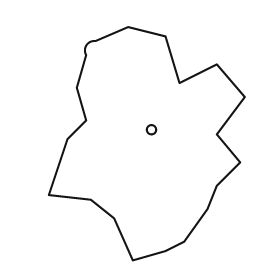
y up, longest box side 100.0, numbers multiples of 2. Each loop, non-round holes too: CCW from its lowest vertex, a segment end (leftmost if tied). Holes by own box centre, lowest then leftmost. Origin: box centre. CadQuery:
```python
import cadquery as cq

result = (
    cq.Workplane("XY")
    .moveTo(-6.0, -50.0)
    .lineTo(8.0, -46.0)
    .lineTo(16.0, -42.0)
    .lineTo(26.0, -28.0)
    .lineTo(30.0, -18.0)
    .lineTo(40.0, -8.0)
    .lineTo(30.0, 4.0)
    .lineTo(42.0, 20.0)
    .lineTo(30.0, 34.0)
    .lineTo(14.0, 26.0)
    .lineTo(8.0, 46.0)
    .lineTo(-8.0, 50.0)
    .lineTo(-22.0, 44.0)
    .threePointArc((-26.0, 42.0), (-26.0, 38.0))
    .lineTo(-30.0, 24.0)
    .lineTo(-26.0, 10.0)
    .lineTo(-34.0, 2.0)
    .lineTo(-42.0, -22.0)
    .lineTo(-24.0, -24.0)
    .lineTo(-14.0, -32.0)
    .close()
    .moveTo(2.0, 6.0)
    .circle(2.0)
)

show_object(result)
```